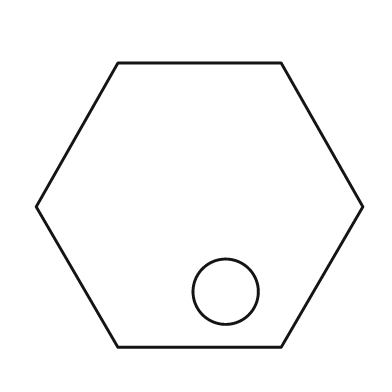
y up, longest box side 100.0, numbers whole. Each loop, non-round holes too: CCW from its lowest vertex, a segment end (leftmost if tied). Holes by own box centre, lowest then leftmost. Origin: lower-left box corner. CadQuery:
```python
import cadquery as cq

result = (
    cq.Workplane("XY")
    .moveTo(25.0, 0.0)
    .lineTo(75.0, 0.0)
    .lineTo(100.0, 43.0)
    .lineTo(75.0, 87.0)
    .lineTo(25.0, 87.0)
    .lineTo(0.0, 43.0)
    .close()
    .moveTo(58.0, 17.0)
    .circle(10.0)
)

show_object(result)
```